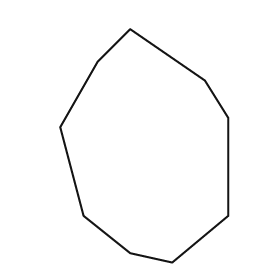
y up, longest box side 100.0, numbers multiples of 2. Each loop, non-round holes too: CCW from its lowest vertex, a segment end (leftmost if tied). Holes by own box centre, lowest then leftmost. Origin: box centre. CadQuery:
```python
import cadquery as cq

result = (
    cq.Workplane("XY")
    .moveTo(12.0, -50.0)
    .lineTo(36.0, -30.0)
    .lineTo(36.0, 12.0)
    .lineTo(26.0, 28.0)
    .lineTo(-6.0, 50.0)
    .lineTo(-20.0, 36.0)
    .lineTo(-36.0, 8.0)
    .lineTo(-26.0, -30.0)
    .lineTo(-6.0, -46.0)
    .close()
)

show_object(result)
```